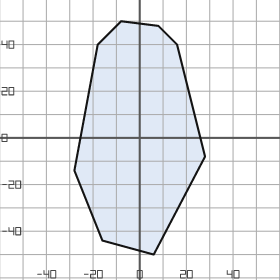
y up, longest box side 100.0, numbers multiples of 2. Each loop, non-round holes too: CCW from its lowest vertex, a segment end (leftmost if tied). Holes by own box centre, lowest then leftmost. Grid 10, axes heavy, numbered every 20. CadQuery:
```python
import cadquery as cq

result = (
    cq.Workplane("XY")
    .moveTo(6.0, -50.0)
    .lineTo(28.0, -8.0)
    .lineTo(16.0, 40.0)
    .lineTo(8.0, 48.0)
    .lineTo(-8.0, 50.0)
    .lineTo(-18.0, 40.0)
    .lineTo(-28.0, -14.0)
    .lineTo(-16.0, -44.0)
    .close()
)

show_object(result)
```